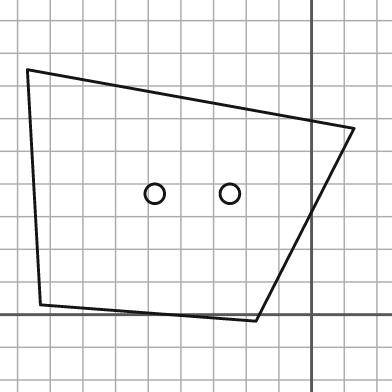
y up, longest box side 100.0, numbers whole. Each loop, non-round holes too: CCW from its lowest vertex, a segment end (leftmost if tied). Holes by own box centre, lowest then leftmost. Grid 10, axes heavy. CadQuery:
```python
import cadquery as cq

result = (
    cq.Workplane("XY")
    .moveTo(-17.0, -2.0)
    .lineTo(13.0, 57.0)
    .lineTo(-87.0, 75.0)
    .lineTo(-83.0, 3.0)
    .close()
    .moveTo(-48.0, 37.0)
    .circle(3.0)
    .moveTo(-25.0, 37.0)
    .circle(3.0)
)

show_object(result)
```